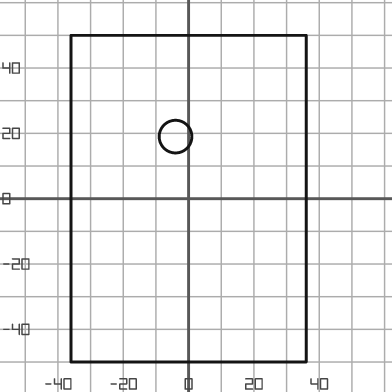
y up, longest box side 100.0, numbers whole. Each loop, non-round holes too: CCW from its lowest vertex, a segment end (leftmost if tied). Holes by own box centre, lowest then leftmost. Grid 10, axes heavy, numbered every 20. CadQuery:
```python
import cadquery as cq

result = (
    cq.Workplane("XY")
    .moveTo(-36.0, -50.0)
    .lineTo(36.0, -50.0)
    .lineTo(36.0, 50.0)
    .lineTo(-36.0, 50.0)
    .close()
    .moveTo(-4.0, 19.0)
    .circle(5.0)
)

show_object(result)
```